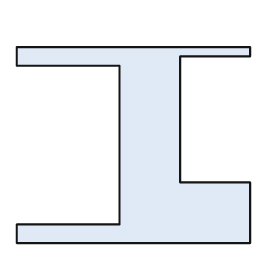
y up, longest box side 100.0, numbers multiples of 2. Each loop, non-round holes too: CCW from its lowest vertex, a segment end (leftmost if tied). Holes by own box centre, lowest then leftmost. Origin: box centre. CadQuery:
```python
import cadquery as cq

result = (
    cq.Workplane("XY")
    .moveTo(-50.0, -42.0)
    .lineTo(50.0, -42.0)
    .lineTo(50.0, -16.0)
    .lineTo(20.0, -16.0)
    .lineTo(20.0, 38.0)
    .lineTo(50.0, 38.0)
    .lineTo(50.0, 42.0)
    .lineTo(-50.0, 42.0)
    .lineTo(-50.0, 34.0)
    .lineTo(-6.0, 34.0)
    .lineTo(-6.0, -34.0)
    .lineTo(-50.0, -34.0)
    .close()
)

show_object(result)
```